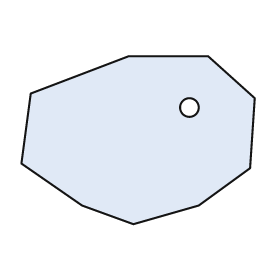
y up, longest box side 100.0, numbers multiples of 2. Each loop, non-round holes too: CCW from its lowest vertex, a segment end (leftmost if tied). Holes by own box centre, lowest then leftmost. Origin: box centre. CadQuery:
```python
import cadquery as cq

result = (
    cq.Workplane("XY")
    .moveTo(-2.0, -36.0)
    .lineTo(26.0, -28.0)
    .lineTo(48.0, -12.0)
    .lineTo(50.0, 18.0)
    .lineTo(30.0, 36.0)
    .lineTo(-4.0, 36.0)
    .lineTo(-46.0, 20.0)
    .lineTo(-50.0, -10.0)
    .lineTo(-24.0, -28.0)
    .close()
    .moveTo(22.0, 14.0)
    .circle(4.0)
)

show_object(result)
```